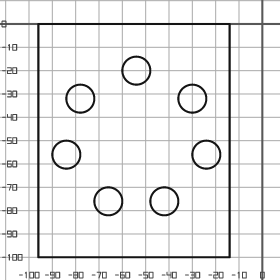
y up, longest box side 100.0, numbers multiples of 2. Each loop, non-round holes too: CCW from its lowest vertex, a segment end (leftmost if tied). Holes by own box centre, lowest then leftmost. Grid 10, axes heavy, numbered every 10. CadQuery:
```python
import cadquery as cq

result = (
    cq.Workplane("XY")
    .moveTo(-96.0, -100.0)
    .lineTo(-14.0, -100.0)
    .lineTo(-14.0, 0.0)
    .lineTo(-96.0, 0.0)
    .close()
    .moveTo(-66.0, -76.0)
    .circle(6.0)
    .moveTo(-42.0, -76.0)
    .circle(6.0)
    .moveTo(-84.0, -56.0)
    .circle(6.0)
    .moveTo(-24.0, -56.0)
    .circle(6.0)
    .moveTo(-78.0, -32.0)
    .circle(6.0)
    .moveTo(-30.0, -32.0)
    .circle(6.0)
    .moveTo(-54.0, -20.0)
    .circle(6.0)
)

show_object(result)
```